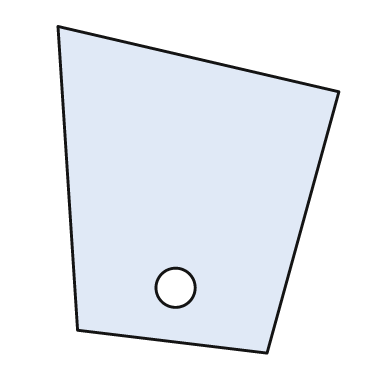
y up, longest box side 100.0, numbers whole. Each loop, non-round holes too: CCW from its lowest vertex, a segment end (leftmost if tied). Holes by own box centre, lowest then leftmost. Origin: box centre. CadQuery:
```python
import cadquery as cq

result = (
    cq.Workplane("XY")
    .moveTo(21.0, -50.0)
    .lineTo(43.0, 30.0)
    .lineTo(-43.0, 50.0)
    .lineTo(-37.0, -43.0)
    .close()
    .moveTo(-7.0, -30.0)
    .circle(6.0)
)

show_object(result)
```